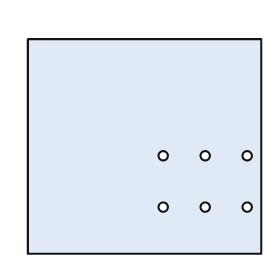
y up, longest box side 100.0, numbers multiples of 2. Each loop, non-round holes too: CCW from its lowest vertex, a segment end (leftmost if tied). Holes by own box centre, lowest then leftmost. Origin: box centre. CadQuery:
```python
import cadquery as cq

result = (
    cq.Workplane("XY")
    .moveTo(-50.0, -46.0)
    .lineTo(50.0, -46.0)
    .lineTo(50.0, 46.0)
    .lineTo(-50.0, 46.0)
    .close()
    .moveTo(8.0, -26.0)
    .circle(2.0)
    .moveTo(26.0, -26.0)
    .circle(2.0)
    .moveTo(44.0, -26.0)
    .circle(2.0)
    .moveTo(8.0, -4.0)
    .circle(2.0)
    .moveTo(26.0, -4.0)
    .circle(2.0)
    .moveTo(44.0, -4.0)
    .circle(2.0)
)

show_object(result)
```